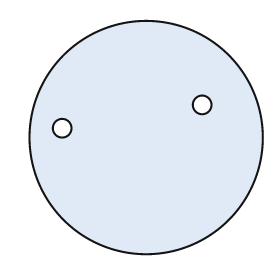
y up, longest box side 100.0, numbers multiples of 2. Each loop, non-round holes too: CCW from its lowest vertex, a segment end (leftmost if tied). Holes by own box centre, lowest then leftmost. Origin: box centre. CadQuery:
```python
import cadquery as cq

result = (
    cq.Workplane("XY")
    .moveTo(0.0, 0.0)
    .circle(50.0)
    .moveTo(-36.0, 4.0)
    .circle(4.0)
    .moveTo(24.0, 14.0)
    .circle(4.0)
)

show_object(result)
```